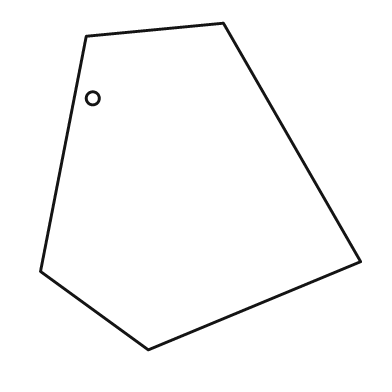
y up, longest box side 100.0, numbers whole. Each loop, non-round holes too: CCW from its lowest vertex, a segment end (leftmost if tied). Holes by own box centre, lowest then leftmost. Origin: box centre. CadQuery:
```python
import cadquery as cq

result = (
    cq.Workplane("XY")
    .moveTo(-16.0, -50.0)
    .lineTo(49.0, -23.0)
    .lineTo(7.0, 50.0)
    .lineTo(-35.0, 46.0)
    .lineTo(-49.0, -26.0)
    .close()
    .moveTo(-33.0, 27.0)
    .circle(2.0)
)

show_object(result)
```